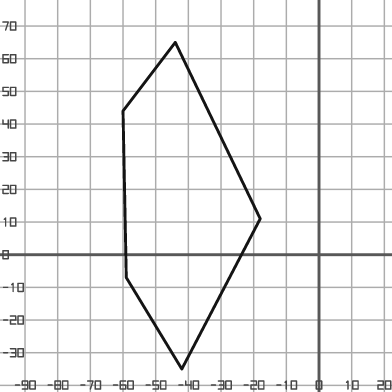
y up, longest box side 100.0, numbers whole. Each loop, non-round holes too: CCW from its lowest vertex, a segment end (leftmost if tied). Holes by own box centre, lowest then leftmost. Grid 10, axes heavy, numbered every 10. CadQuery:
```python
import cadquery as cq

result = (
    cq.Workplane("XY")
    .moveTo(-42.0, -35.0)
    .lineTo(-18.0, 11.0)
    .lineTo(-44.0, 65.0)
    .lineTo(-60.0, 44.0)
    .lineTo(-59.0, -7.0)
    .close()
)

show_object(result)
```